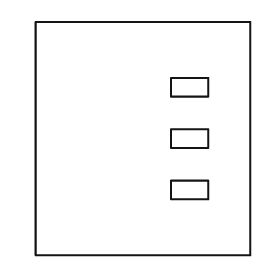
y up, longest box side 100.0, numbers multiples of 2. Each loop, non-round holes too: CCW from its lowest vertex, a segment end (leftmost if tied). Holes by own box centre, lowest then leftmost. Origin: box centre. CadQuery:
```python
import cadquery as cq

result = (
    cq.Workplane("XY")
    .moveTo(-46.0, -50.0)
    .lineTo(46.0, -50.0)
    .lineTo(46.0, 50.0)
    .lineTo(-46.0, 50.0)
    .close()
    .moveTo(12.0, -26.0)
    .lineTo(28.0, -26.0)
    .lineTo(28.0, -18.0)
    .lineTo(12.0, -18.0)
    .close()
    .moveTo(12.0, -4.0)
    .lineTo(28.0, -4.0)
    .lineTo(28.0, 4.0)
    .lineTo(12.0, 4.0)
    .close()
    .moveTo(12.0, 18.0)
    .lineTo(28.0, 18.0)
    .lineTo(28.0, 26.0)
    .lineTo(12.0, 26.0)
    .close()
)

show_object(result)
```